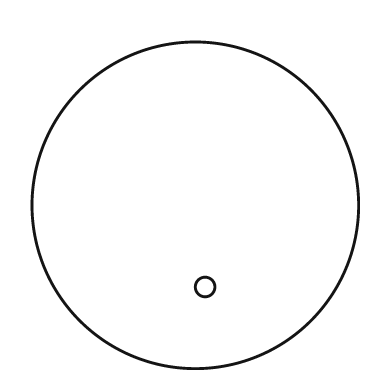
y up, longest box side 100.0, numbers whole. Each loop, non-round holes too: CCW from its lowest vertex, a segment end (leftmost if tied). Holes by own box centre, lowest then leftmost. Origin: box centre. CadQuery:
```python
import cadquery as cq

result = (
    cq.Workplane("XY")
    .moveTo(0.0, 0.0)
    .circle(50.0)
    .moveTo(3.0, -25.0)
    .circle(3.0)
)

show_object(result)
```